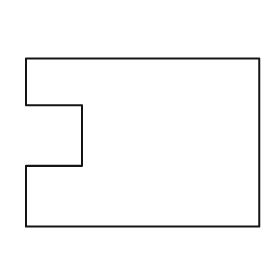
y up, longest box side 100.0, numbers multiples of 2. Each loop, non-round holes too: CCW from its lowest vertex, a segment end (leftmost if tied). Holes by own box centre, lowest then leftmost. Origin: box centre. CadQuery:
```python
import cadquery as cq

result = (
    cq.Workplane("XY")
    .moveTo(-50.0, -36.0)
    .lineTo(50.0, -36.0)
    .lineTo(50.0, 36.0)
    .lineTo(-50.0, 36.0)
    .lineTo(-50.0, 16.0)
    .lineTo(-26.0, 16.0)
    .lineTo(-26.0, -10.0)
    .lineTo(-50.0, -10.0)
    .close()
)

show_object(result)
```